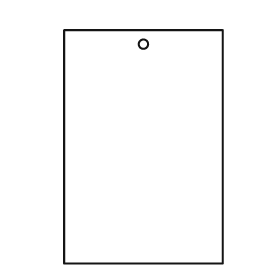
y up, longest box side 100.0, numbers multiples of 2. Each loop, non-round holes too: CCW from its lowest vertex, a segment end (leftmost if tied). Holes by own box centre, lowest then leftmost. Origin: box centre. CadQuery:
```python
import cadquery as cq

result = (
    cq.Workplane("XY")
    .moveTo(-34.0, -50.0)
    .lineTo(34.0, -50.0)
    .lineTo(34.0, 50.0)
    .lineTo(-34.0, 50.0)
    .close()
    .moveTo(0.0, 44.0)
    .circle(2.0)
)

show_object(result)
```